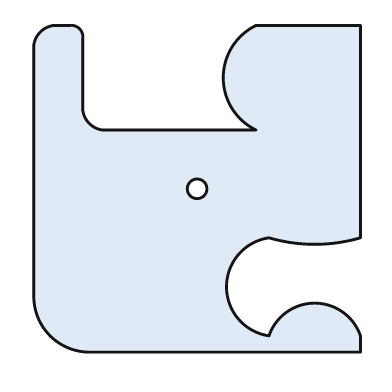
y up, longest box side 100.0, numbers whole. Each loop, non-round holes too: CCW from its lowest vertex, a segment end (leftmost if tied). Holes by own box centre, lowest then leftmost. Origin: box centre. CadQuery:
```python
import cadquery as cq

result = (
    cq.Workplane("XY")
    .moveTo(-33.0, -50.0)
    .lineTo(50.0, -50.0)
    .lineTo(50.0, -45.0)
    .threePointArc((36.0, -35.0), (22.0, -45.0))
    .threePointArc((9.0, -30.0), (22.0, -15.0))
    .threePointArc((36.0, -17.0), (50.0, -15.0))
    .lineTo(50.0, 50.0)
    .lineTo(18.0, 50.0)
    .threePointArc((8.0, 34.0), (18.0, 18.0))
    .lineTo(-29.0, 18.0)
    .threePointArc((-33.0, 20.0), (-35.0, 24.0))
    .lineTo(-35.0, 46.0)
    .threePointArc((-36.0, 49.0), (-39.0, 50.0))
    .lineTo(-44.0, 50.0)
    .threePointArc((-48.0, 48.0), (-50.0, 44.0))
    .lineTo(-50.0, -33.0)
    .threePointArc((-45.0, -45.0), (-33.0, -50.0))
    .close()
    .moveTo(0.0, 0.0)
    .circle(3.0)
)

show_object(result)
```